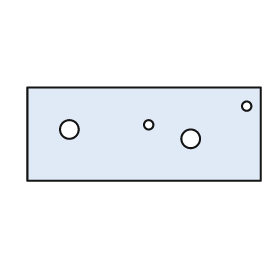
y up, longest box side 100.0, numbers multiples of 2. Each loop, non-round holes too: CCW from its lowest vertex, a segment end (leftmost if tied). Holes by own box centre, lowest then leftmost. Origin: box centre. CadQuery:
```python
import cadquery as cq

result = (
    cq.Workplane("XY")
    .moveTo(-50.0, -20.0)
    .lineTo(50.0, -20.0)
    .lineTo(50.0, 20.0)
    .lineTo(-50.0, 20.0)
    .close()
    .moveTo(20.0, -2.0)
    .circle(4.0)
    .moveTo(-32.0, 2.0)
    .circle(4.0)
    .moveTo(2.0, 4.0)
    .circle(2.0)
    .moveTo(44.0, 12.0)
    .circle(2.0)
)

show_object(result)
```